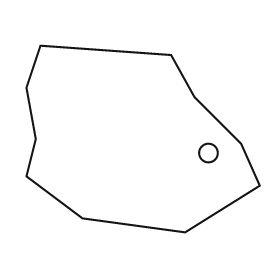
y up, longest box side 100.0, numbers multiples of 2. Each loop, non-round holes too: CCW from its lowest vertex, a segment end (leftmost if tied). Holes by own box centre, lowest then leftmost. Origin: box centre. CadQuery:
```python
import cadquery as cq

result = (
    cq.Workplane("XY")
    .moveTo(18.0, -40.0)
    .lineTo(50.0, -20.0)
    .lineTo(42.0, -2.0)
    .lineTo(22.0, 18.0)
    .lineTo(12.0, 36.0)
    .lineTo(-44.0, 40.0)
    .lineTo(-50.0, 22.0)
    .lineTo(-46.0, 0.0)
    .lineTo(-50.0, -16.0)
    .lineTo(-26.0, -34.0)
    .close()
    .moveTo(28.0, -6.0)
    .circle(4.0)
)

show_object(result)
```